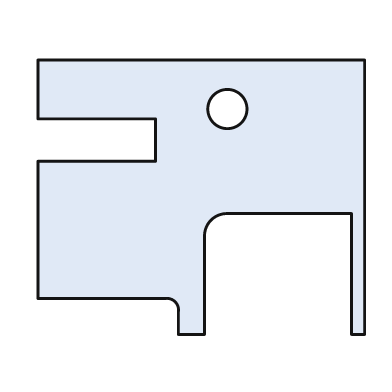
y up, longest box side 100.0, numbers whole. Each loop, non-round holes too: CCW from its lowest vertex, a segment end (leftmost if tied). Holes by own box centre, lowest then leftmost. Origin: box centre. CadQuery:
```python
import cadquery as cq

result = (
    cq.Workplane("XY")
    .moveTo(-7.0, -42.0)
    .lineTo(1.0, -42.0)
    .lineTo(1.0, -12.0)
    .threePointArc((3.0, -7.0), (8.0, -5.0))
    .lineTo(46.0, -5.0)
    .lineTo(46.0, -42.0)
    .lineTo(50.0, -42.0)
    .lineTo(50.0, 42.0)
    .lineTo(-50.0, 42.0)
    .lineTo(-50.0, 24.0)
    .lineTo(-14.0, 24.0)
    .lineTo(-14.0, 11.0)
    .lineTo(-50.0, 11.0)
    .lineTo(-50.0, -31.0)
    .lineTo(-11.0, -31.0)
    .threePointArc((-8.0, -32.0), (-7.0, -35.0))
    .close()
    .moveTo(8.0, 27.0)
    .circle(6.0)
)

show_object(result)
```